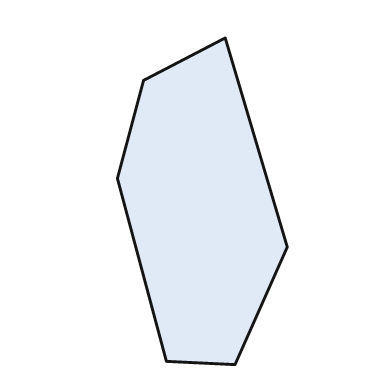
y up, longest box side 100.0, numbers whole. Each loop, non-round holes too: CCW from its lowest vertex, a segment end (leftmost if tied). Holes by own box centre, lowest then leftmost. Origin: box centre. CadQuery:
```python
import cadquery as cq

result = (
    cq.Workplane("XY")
    .moveTo(10.0, -50.0)
    .lineTo(26.0, -14.0)
    .lineTo(7.0, 50.0)
    .lineTo(-18.0, 37.0)
    .lineTo(-26.0, 7.0)
    .lineTo(-11.0, -49.0)
    .close()
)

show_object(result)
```